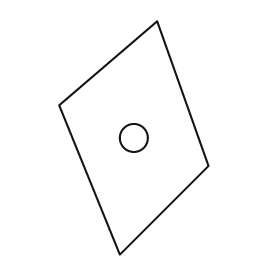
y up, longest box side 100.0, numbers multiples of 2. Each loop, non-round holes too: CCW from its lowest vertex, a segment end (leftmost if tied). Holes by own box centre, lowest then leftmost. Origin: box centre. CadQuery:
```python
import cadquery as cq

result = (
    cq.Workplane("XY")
    .moveTo(-6.0, -50.0)
    .lineTo(32.0, -12.0)
    .lineTo(10.0, 50.0)
    .lineTo(-32.0, 14.0)
    .close()
    .moveTo(0.0, 0.0)
    .circle(6.0)
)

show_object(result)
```